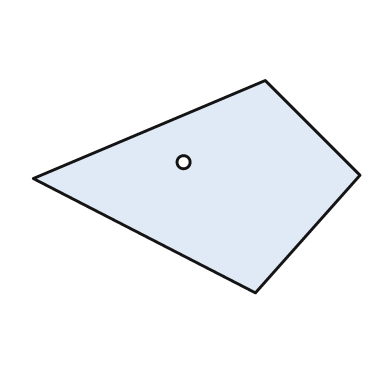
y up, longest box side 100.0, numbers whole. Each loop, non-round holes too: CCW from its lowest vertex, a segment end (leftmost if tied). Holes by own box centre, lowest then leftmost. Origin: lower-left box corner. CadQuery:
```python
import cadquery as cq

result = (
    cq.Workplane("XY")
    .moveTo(68.0, 0.0)
    .lineTo(100.0, 36.0)
    .lineTo(71.0, 65.0)
    .lineTo(0.0, 35.0)
    .close()
    .moveTo(46.0, 40.0)
    .circle(2.0)
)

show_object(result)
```